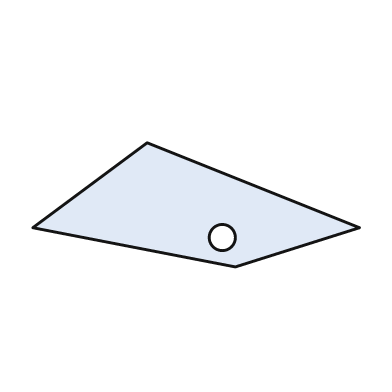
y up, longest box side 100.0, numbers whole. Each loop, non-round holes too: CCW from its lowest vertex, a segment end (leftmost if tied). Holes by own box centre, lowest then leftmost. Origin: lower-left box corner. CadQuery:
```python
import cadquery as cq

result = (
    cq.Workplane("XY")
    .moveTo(62.0, 0.0)
    .lineTo(100.0, 12.0)
    .lineTo(35.0, 38.0)
    .lineTo(0.0, 12.0)
    .close()
    .moveTo(58.0, 9.0)
    .circle(4.0)
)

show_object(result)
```